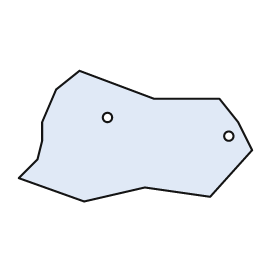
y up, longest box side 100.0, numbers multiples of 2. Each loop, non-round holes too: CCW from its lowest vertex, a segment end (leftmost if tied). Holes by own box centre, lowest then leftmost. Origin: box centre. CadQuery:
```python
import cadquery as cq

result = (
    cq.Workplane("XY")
    .moveTo(-22.0, -28.0)
    .lineTo(4.0, -22.0)
    .lineTo(32.0, -26.0)
    .lineTo(50.0, -6.0)
    .lineTo(44.0, 6.0)
    .lineTo(36.0, 16.0)
    .lineTo(8.0, 16.0)
    .lineTo(-24.0, 28.0)
    .lineTo(-34.0, 20.0)
    .lineTo(-40.0, 6.0)
    .lineTo(-40.0, -2.0)
    .lineTo(-42.0, -10.0)
    .lineTo(-50.0, -18.0)
    .close()
    .moveTo(40.0, 0.0)
    .circle(2.0)
    .moveTo(-12.0, 8.0)
    .circle(2.0)
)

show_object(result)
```